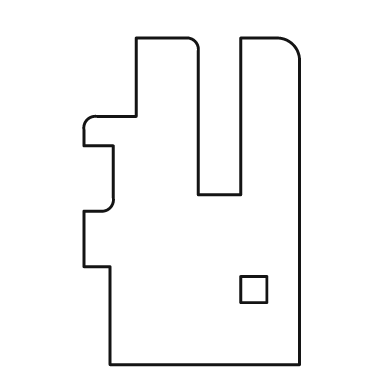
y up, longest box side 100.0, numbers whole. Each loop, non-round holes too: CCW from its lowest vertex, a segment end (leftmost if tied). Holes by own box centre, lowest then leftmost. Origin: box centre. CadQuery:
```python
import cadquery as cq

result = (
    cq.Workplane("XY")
    .moveTo(-25.0, -50.0)
    .lineTo(33.0, -50.0)
    .lineTo(33.0, 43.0)
    .threePointArc((31.0, 48.0), (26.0, 50.0))
    .lineTo(15.0, 50.0)
    .lineTo(15.0, 2.0)
    .lineTo(2.0, 2.0)
    .lineTo(2.0, 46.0)
    .threePointArc((1.0, 49.0), (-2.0, 50.0))
    .lineTo(-17.0, 50.0)
    .lineTo(-17.0, 26.0)
    .lineTo(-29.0, 26.0)
    .threePointArc((-32.0, 25.0), (-33.0, 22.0))
    .lineTo(-33.0, 17.0)
    .lineTo(-24.0, 17.0)
    .lineTo(-24.0, 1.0)
    .threePointArc((-25.0, -2.0), (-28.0, -3.0))
    .lineTo(-33.0, -3.0)
    .lineTo(-33.0, -20.0)
    .lineTo(-25.0, -20.0)
    .close()
    .moveTo(15.0, -31.0)
    .lineTo(23.0, -31.0)
    .lineTo(23.0, -23.0)
    .lineTo(15.0, -23.0)
    .close()
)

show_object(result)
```